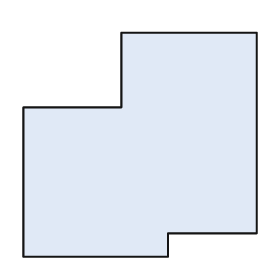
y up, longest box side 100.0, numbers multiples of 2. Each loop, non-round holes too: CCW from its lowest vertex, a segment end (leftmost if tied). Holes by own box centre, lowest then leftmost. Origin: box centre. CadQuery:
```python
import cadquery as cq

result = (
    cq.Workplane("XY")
    .moveTo(-50.0, -48.0)
    .lineTo(12.0, -48.0)
    .lineTo(12.0, -38.0)
    .lineTo(50.0, -38.0)
    .lineTo(50.0, 48.0)
    .lineTo(-8.0, 48.0)
    .lineTo(-8.0, 16.0)
    .lineTo(-50.0, 16.0)
    .close()
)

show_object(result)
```